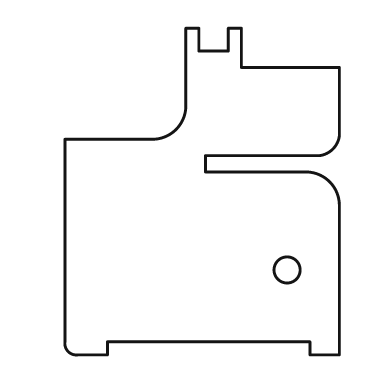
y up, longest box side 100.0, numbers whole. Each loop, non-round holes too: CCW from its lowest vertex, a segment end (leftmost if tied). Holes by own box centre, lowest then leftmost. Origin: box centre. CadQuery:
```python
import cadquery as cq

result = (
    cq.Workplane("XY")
    .moveTo(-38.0, -50.0)
    .lineTo(-29.0, -50.0)
    .lineTo(-29.0, -46.0)
    .lineTo(33.0, -46.0)
    .lineTo(33.0, -50.0)
    .lineTo(42.0, -50.0)
    .lineTo(42.0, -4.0)
    .threePointArc((39.0, 3.0), (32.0, 6.0))
    .lineTo(1.0, 6.0)
    .lineTo(1.0, 11.0)
    .lineTo(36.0, 11.0)
    .threePointArc((40.0, 13.0), (42.0, 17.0))
    .lineTo(42.0, 38.0)
    .lineTo(12.0, 38.0)
    .lineTo(12.0, 50.0)
    .lineTo(8.0, 50.0)
    .lineTo(8.0, 43.0)
    .lineTo(-1.0, 43.0)
    .lineTo(-1.0, 50.0)
    .lineTo(-5.0, 50.0)
    .lineTo(-5.0, 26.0)
    .threePointArc((-8.0, 19.0), (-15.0, 16.0))
    .lineTo(-42.0, 16.0)
    .lineTo(-42.0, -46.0)
    .threePointArc((-41.0, -49.0), (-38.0, -50.0))
    .close()
    .moveTo(26.0, -24.0)
    .circle(4.0)
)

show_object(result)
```